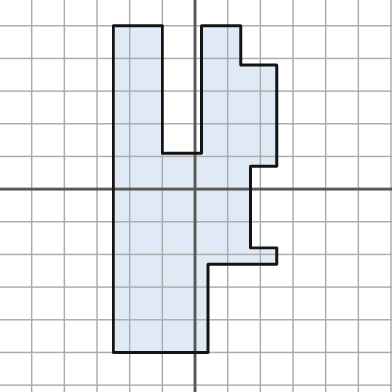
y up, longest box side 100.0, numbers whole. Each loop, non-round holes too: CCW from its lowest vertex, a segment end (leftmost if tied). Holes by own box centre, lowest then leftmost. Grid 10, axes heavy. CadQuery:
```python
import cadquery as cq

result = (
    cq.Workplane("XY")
    .moveTo(-25.0, -50.0)
    .lineTo(4.0, -50.0)
    .lineTo(4.0, -23.0)
    .lineTo(25.0, -23.0)
    .lineTo(25.0, -18.0)
    .lineTo(17.0, -18.0)
    .lineTo(17.0, 7.0)
    .lineTo(25.0, 7.0)
    .lineTo(25.0, 38.0)
    .lineTo(14.0, 38.0)
    .lineTo(14.0, 50.0)
    .lineTo(2.0, 50.0)
    .lineTo(2.0, 11.0)
    .lineTo(-10.0, 11.0)
    .lineTo(-10.0, 50.0)
    .lineTo(-25.0, 50.0)
    .close()
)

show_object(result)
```